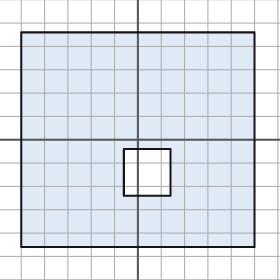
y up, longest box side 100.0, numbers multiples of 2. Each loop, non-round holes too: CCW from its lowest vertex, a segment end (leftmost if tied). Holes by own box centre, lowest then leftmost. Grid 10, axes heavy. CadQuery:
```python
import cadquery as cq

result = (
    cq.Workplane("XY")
    .moveTo(-50.0, -46.0)
    .lineTo(50.0, -46.0)
    .lineTo(50.0, 46.0)
    .lineTo(-50.0, 46.0)
    .close()
    .moveTo(-6.0, -24.0)
    .lineTo(14.0, -24.0)
    .lineTo(14.0, -4.0)
    .lineTo(-6.0, -4.0)
    .close()
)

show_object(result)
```